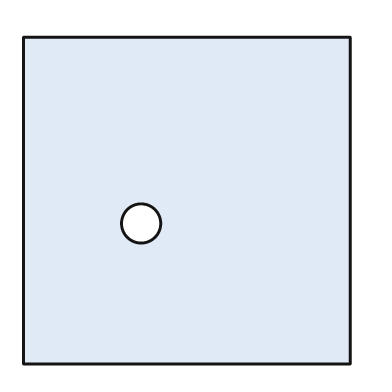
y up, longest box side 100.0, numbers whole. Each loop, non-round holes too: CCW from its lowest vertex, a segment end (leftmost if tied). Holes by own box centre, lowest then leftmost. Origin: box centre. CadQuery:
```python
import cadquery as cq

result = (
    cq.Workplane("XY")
    .moveTo(-50.0, -50.0)
    .lineTo(50.0, -50.0)
    .lineTo(50.0, 50.0)
    .lineTo(-50.0, 50.0)
    .close()
    .moveTo(-14.0, -7.0)
    .circle(6.0)
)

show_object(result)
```